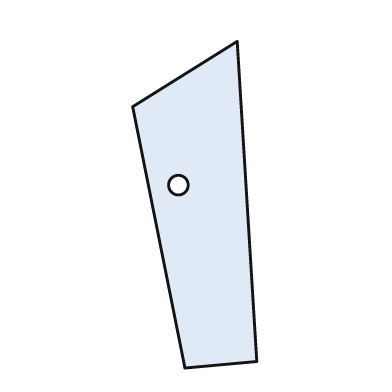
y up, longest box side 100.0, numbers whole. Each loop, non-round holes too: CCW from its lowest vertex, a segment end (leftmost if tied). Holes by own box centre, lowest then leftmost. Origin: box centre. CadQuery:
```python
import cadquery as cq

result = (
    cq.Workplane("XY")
    .moveTo(-3.0, -50.0)
    .lineTo(19.0, -48.0)
    .lineTo(13.0, 50.0)
    .lineTo(-19.0, 30.0)
    .close()
    .moveTo(-5.0, 6.0)
    .circle(3.0)
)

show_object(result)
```